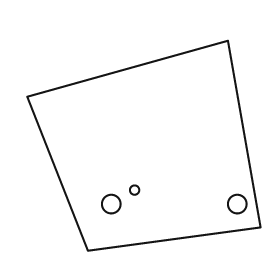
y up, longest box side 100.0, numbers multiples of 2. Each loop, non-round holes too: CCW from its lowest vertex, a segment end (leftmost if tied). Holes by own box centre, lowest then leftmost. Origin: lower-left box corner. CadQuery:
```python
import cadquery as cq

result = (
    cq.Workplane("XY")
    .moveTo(26.0, 0.0)
    .lineTo(100.0, 10.0)
    .lineTo(86.0, 90.0)
    .lineTo(0.0, 66.0)
    .close()
    .moveTo(36.0, 20.0)
    .circle(4.0)
    .moveTo(90.0, 20.0)
    .circle(4.0)
    .moveTo(46.0, 26.0)
    .circle(2.0)
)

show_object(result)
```